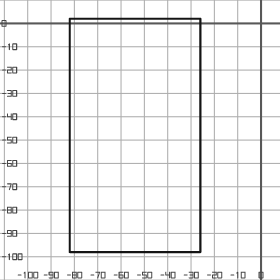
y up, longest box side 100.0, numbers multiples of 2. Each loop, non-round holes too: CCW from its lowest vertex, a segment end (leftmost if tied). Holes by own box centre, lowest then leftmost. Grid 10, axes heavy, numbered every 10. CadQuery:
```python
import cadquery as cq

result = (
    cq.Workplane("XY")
    .moveTo(-82.0, -98.0)
    .lineTo(-26.0, -98.0)
    .lineTo(-26.0, 2.0)
    .lineTo(-82.0, 2.0)
    .close()
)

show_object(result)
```